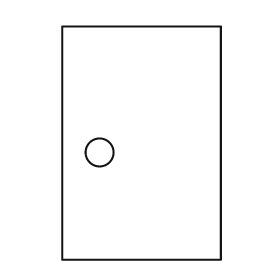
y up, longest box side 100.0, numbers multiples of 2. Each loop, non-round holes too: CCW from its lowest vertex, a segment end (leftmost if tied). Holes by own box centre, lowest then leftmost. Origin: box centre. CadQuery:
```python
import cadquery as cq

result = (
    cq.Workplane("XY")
    .moveTo(-34.0, -50.0)
    .lineTo(34.0, -50.0)
    .lineTo(34.0, 50.0)
    .lineTo(-34.0, 50.0)
    .close()
    .moveTo(-18.0, -4.0)
    .circle(6.0)
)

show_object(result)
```